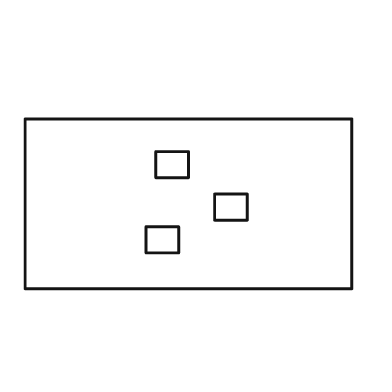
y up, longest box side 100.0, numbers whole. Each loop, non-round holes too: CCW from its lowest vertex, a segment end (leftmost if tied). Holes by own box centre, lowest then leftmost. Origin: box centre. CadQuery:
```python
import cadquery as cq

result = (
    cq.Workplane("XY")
    .moveTo(-50.0, -26.0)
    .lineTo(50.0, -26.0)
    .lineTo(50.0, 26.0)
    .lineTo(-50.0, 26.0)
    .close()
    .moveTo(-13.0, -15.0)
    .lineTo(-3.0, -15.0)
    .lineTo(-3.0, -7.0)
    .lineTo(-13.0, -7.0)
    .close()
    .moveTo(8.0, -5.0)
    .lineTo(18.0, -5.0)
    .lineTo(18.0, 3.0)
    .lineTo(8.0, 3.0)
    .close()
    .moveTo(-10.0, 8.0)
    .lineTo(0.0, 8.0)
    .lineTo(0.0, 16.0)
    .lineTo(-10.0, 16.0)
    .close()
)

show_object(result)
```